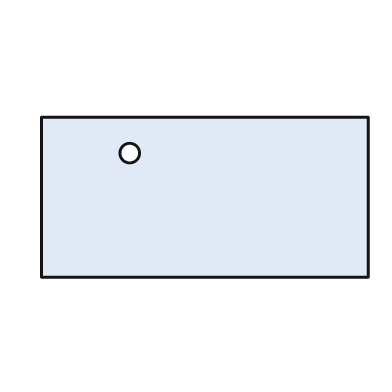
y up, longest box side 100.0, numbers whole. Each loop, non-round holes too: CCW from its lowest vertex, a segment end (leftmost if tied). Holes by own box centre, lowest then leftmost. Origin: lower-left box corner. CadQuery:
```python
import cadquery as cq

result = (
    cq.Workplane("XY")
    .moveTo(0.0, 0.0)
    .lineTo(100.0, 0.0)
    .lineTo(100.0, 49.0)
    .lineTo(0.0, 49.0)
    .close()
    .moveTo(27.0, 38.0)
    .circle(3.0)
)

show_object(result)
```